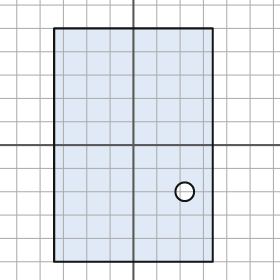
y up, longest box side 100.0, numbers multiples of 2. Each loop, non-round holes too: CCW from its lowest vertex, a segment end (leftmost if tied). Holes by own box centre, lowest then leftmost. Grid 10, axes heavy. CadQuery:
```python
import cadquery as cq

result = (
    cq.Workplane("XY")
    .moveTo(-34.0, -50.0)
    .lineTo(34.0, -50.0)
    .lineTo(34.0, 50.0)
    .lineTo(-34.0, 50.0)
    .close()
    .moveTo(22.0, -20.0)
    .circle(4.0)
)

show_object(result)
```